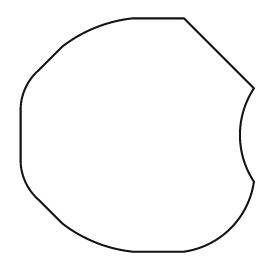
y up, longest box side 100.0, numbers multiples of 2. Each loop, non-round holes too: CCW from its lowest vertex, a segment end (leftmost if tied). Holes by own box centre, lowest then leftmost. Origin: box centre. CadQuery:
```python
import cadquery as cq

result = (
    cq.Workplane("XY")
    .moveTo(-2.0, -50.0)
    .lineTo(20.0, -50.0)
    .threePointArc((40.0, -40.0), (50.0, -20.0))
    .threePointArc((44.0, 0.0), (50.0, 20.0))
    .lineTo(20.0, 50.0)
    .lineTo(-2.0, 50.0)
    .threePointArc((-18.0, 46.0), (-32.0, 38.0))
    .lineTo(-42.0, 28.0)
    .threePointArc((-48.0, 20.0), (-50.0, 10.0))
    .lineTo(-50.0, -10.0)
    .threePointArc((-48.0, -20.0), (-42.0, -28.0))
    .lineTo(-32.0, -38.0)
    .threePointArc((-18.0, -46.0), (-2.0, -50.0))
    .close()
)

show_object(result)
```